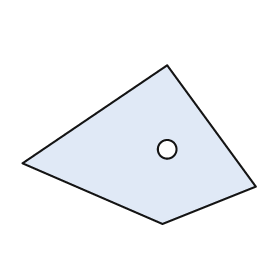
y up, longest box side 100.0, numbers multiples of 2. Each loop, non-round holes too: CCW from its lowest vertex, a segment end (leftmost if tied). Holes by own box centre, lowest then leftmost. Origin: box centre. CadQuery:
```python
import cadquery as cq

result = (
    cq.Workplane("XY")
    .moveTo(10.0, -34.0)
    .lineTo(50.0, -18.0)
    .lineTo(12.0, 34.0)
    .lineTo(-50.0, -8.0)
    .close()
    .moveTo(12.0, -2.0)
    .circle(4.0)
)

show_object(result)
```